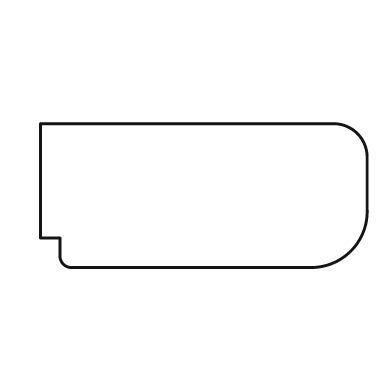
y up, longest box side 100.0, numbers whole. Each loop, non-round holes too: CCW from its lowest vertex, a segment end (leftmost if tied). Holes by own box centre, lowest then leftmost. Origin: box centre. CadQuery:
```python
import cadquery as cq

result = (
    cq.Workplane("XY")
    .moveTo(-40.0, -22.0)
    .lineTo(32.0, -22.0)
    .threePointArc((45.0, -17.0), (50.0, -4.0))
    .lineTo(50.0, 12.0)
    .threePointArc((47.0, 19.0), (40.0, 22.0))
    .lineTo(-50.0, 22.0)
    .lineTo(-50.0, -13.0)
    .lineTo(-44.0, -13.0)
    .lineTo(-44.0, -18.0)
    .threePointArc((-43.0, -21.0), (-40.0, -22.0))
    .close()
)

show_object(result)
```